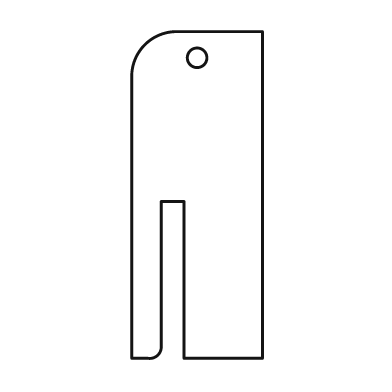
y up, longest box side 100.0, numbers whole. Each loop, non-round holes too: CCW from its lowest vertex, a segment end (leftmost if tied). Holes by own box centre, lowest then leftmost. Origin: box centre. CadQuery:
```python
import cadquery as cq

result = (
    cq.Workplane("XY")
    .moveTo(-20.0, -50.0)
    .lineTo(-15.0, -50.0)
    .threePointArc((-12.0, -49.0), (-11.0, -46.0))
    .lineTo(-11.0, -2.0)
    .lineTo(-4.0, -2.0)
    .lineTo(-4.0, -50.0)
    .lineTo(20.0, -50.0)
    .lineTo(20.0, 50.0)
    .lineTo(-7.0, 50.0)
    .threePointArc((-16.0, 46.0), (-20.0, 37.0))
    .close()
    .moveTo(0.0, 42.0)
    .circle(3.0)
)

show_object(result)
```